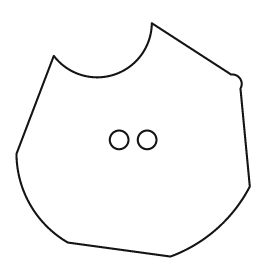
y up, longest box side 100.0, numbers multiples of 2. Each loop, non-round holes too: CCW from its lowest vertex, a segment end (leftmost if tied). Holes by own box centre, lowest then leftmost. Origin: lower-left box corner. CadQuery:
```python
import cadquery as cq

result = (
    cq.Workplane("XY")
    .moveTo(66.0, 0.0)
    .threePointArc((86.0, 12.0), (100.0, 30.0))
    .lineTo(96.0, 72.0)
    .threePointArc((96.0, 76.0), (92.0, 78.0))
    .lineTo(58.0, 100.0)
    .threePointArc((42.0, 78.0), (16.0, 86.0))
    .lineTo(0.0, 44.0)
    .threePointArc((6.0, 22.0), (22.0, 6.0))
    .close()
    .moveTo(44.0, 50.0)
    .circle(4.0)
    .moveTo(56.0, 50.0)
    .circle(4.0)
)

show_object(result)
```